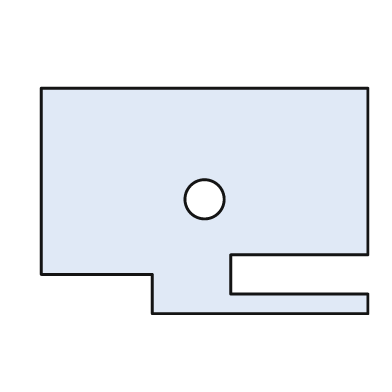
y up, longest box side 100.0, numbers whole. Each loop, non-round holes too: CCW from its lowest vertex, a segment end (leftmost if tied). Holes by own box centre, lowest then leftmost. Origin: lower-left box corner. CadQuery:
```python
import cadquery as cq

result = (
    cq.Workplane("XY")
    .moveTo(34.0, 0.0)
    .lineTo(100.0, 0.0)
    .lineTo(100.0, 6.0)
    .lineTo(58.0, 6.0)
    .lineTo(58.0, 18.0)
    .lineTo(100.0, 18.0)
    .lineTo(100.0, 69.0)
    .lineTo(0.0, 69.0)
    .lineTo(0.0, 12.0)
    .lineTo(34.0, 12.0)
    .close()
    .moveTo(50.0, 35.0)
    .circle(6.0)
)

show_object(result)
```